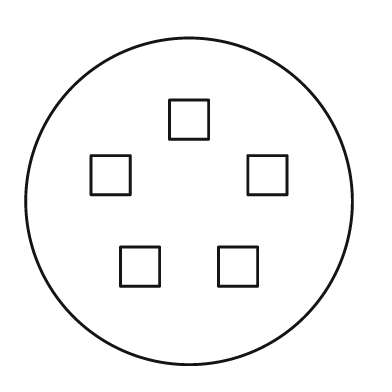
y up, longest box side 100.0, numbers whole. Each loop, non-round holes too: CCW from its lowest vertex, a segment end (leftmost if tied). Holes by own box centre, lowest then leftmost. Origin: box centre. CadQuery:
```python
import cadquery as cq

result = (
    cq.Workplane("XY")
    .moveTo(0.0, 0.0)
    .circle(50.0)
    .moveTo(-21.0, -26.0)
    .lineTo(-9.0, -26.0)
    .lineTo(-9.0, -14.0)
    .lineTo(-21.0, -14.0)
    .close()
    .moveTo(9.0, -26.0)
    .lineTo(21.0, -26.0)
    .lineTo(21.0, -14.0)
    .lineTo(9.0, -14.0)
    .close()
    .moveTo(-30.0, 2.0)
    .lineTo(-18.0, 2.0)
    .lineTo(-18.0, 14.0)
    .lineTo(-30.0, 14.0)
    .close()
    .moveTo(18.0, 2.0)
    .lineTo(30.0, 2.0)
    .lineTo(30.0, 14.0)
    .lineTo(18.0, 14.0)
    .close()
    .moveTo(-6.0, 19.0)
    .lineTo(6.0, 19.0)
    .lineTo(6.0, 31.0)
    .lineTo(-6.0, 31.0)
    .close()
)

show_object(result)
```